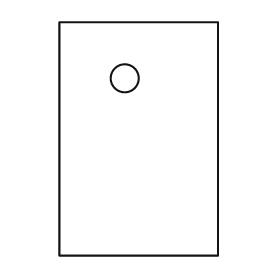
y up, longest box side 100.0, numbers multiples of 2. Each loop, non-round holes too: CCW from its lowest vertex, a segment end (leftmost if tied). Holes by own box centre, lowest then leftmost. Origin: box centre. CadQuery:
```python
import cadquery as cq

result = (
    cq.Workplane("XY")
    .moveTo(-34.0, -50.0)
    .lineTo(34.0, -50.0)
    .lineTo(34.0, 50.0)
    .lineTo(-34.0, 50.0)
    .close()
    .moveTo(-6.0, 26.0)
    .circle(6.0)
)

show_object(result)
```